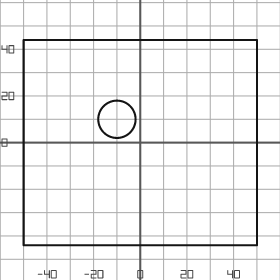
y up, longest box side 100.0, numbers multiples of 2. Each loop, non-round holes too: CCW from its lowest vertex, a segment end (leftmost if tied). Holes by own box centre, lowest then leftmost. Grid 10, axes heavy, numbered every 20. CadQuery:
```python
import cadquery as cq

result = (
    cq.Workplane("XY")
    .moveTo(-50.0, -44.0)
    .lineTo(50.0, -44.0)
    .lineTo(50.0, 44.0)
    .lineTo(-50.0, 44.0)
    .close()
    .moveTo(-10.0, 10.0)
    .circle(8.0)
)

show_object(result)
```